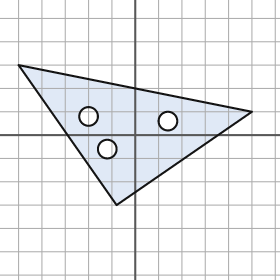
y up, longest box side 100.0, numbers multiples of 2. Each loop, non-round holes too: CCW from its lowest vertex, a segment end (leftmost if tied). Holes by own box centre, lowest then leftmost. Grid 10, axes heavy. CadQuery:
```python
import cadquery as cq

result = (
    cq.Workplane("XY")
    .moveTo(-8.0, -30.0)
    .lineTo(50.0, 10.0)
    .lineTo(-50.0, 30.0)
    .close()
    .moveTo(-12.0, -6.0)
    .circle(4.0)
    .moveTo(14.0, 6.0)
    .circle(4.0)
    .moveTo(-20.0, 8.0)
    .circle(4.0)
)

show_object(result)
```